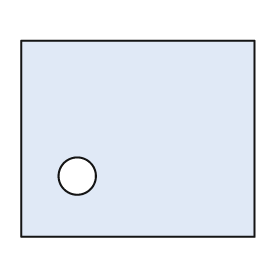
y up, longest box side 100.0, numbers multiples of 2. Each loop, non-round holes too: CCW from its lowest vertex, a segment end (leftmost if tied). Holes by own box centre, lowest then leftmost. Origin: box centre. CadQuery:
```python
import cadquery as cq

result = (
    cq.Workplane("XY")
    .moveTo(-50.0, -42.0)
    .lineTo(50.0, -42.0)
    .lineTo(50.0, 42.0)
    .lineTo(-50.0, 42.0)
    .close()
    .moveTo(-26.0, -16.0)
    .circle(8.0)
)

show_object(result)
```